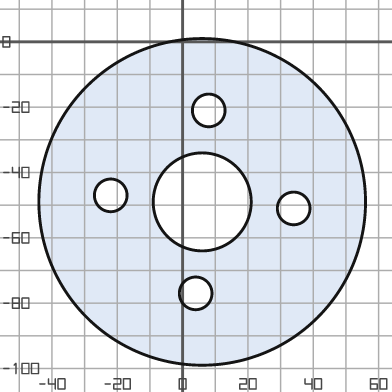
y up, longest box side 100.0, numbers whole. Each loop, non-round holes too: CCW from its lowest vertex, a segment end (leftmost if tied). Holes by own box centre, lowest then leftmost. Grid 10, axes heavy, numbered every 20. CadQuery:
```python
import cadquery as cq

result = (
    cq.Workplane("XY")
    .moveTo(6.0, -49.0)
    .circle(50.0)
    .moveTo(4.0, -77.0)
    .circle(5.0)
    .moveTo(34.0, -51.0)
    .circle(5.0)
    .moveTo(6.0, -49.0)
    .circle(15.0)
    .moveTo(-22.0, -47.0)
    .circle(5.0)
    .moveTo(8.0, -21.0)
    .circle(5.0)
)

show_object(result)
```